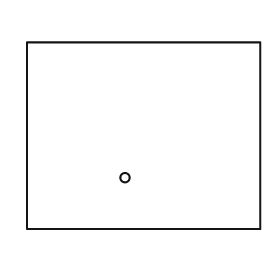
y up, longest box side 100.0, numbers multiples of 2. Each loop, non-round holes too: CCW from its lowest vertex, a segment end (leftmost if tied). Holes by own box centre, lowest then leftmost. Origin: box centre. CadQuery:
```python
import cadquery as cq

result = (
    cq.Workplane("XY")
    .moveTo(-50.0, -40.0)
    .lineTo(50.0, -40.0)
    .lineTo(50.0, 40.0)
    .lineTo(-50.0, 40.0)
    .close()
    .moveTo(-8.0, -18.0)
    .circle(2.0)
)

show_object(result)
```